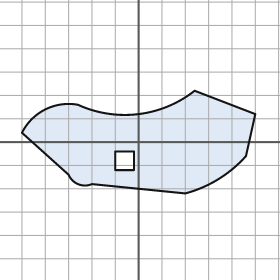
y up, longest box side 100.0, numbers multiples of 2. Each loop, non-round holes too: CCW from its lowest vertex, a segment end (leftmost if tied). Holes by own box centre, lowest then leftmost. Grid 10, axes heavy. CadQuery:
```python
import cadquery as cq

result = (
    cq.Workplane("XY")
    .moveTo(20.0, -22.0)
    .threePointArc((34.0, -16.0), (46.0, -6.0))
    .lineTo(50.0, 12.0)
    .lineTo(24.0, 22.0)
    .threePointArc((0.0, 12.0), (-26.0, 16.0))
    .threePointArc((-40.0, 14.0), (-50.0, 4.0))
    .lineTo(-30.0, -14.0)
    .threePointArc((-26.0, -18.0), (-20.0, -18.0))
    .close()
    .moveTo(-10.0, -12.0)
    .lineTo(-2.0, -12.0)
    .lineTo(-2.0, -4.0)
    .lineTo(-10.0, -4.0)
    .close()
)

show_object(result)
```